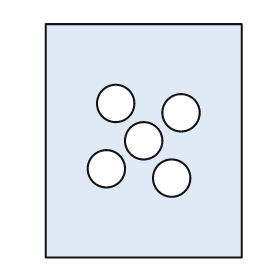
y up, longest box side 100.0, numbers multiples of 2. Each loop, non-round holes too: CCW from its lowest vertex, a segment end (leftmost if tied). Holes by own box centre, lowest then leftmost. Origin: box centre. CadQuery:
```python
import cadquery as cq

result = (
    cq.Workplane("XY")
    .moveTo(-42.0, -50.0)
    .lineTo(42.0, -50.0)
    .lineTo(42.0, 50.0)
    .lineTo(-42.0, 50.0)
    .close()
    .moveTo(12.0, -16.0)
    .circle(8.0)
    .moveTo(-16.0, -12.0)
    .circle(8.0)
    .moveTo(0.0, 0.0)
    .circle(8.0)
    .moveTo(16.0, 12.0)
    .circle(8.0)
    .moveTo(-12.0, 16.0)
    .circle(8.0)
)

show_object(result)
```